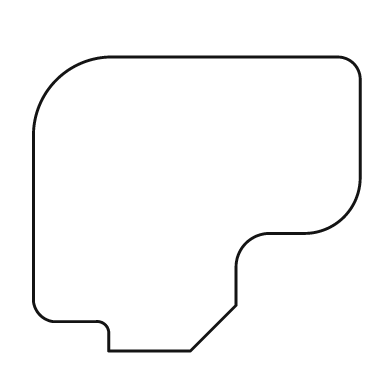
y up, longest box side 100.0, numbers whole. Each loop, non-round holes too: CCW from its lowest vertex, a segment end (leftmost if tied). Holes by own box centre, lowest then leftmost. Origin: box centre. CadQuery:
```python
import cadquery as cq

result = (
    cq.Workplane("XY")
    .moveTo(-27.0, -45.0)
    .lineTo(-2.0, -45.0)
    .lineTo(12.0, -31.0)
    .lineTo(12.0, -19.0)
    .threePointArc((15.0, -12.0), (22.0, -9.0))
    .lineTo(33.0, -9.0)
    .threePointArc((45.0, -4.0), (50.0, 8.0))
    .lineTo(50.0, 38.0)
    .threePointArc((48.0, 43.0), (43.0, 45.0))
    .lineTo(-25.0, 45.0)
    .threePointArc((-43.0, 38.0), (-50.0, 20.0))
    .lineTo(-50.0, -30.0)
    .threePointArc((-48.0, -34.0), (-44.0, -36.0))
    .lineTo(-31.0, -36.0)
    .threePointArc((-28.0, -37.0), (-27.0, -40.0))
    .close()
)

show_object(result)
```